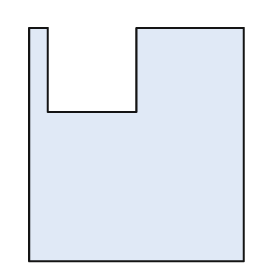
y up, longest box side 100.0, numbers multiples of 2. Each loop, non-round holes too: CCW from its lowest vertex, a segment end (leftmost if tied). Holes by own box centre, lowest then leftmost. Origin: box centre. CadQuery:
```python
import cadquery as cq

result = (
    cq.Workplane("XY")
    .moveTo(-46.0, -50.0)
    .lineTo(46.0, -50.0)
    .lineTo(46.0, 50.0)
    .lineTo(0.0, 50.0)
    .lineTo(0.0, 14.0)
    .lineTo(-38.0, 14.0)
    .lineTo(-38.0, 50.0)
    .lineTo(-46.0, 50.0)
    .close()
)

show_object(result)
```